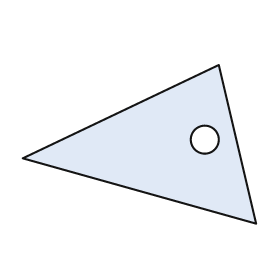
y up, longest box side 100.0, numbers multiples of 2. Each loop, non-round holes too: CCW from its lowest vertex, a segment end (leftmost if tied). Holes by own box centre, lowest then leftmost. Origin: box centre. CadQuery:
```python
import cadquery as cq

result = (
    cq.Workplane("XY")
    .moveTo(50.0, -34.0)
    .lineTo(34.0, 34.0)
    .lineTo(-50.0, -6.0)
    .close()
    .moveTo(28.0, 2.0)
    .circle(6.0)
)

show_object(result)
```